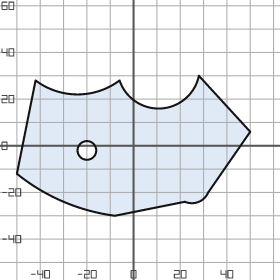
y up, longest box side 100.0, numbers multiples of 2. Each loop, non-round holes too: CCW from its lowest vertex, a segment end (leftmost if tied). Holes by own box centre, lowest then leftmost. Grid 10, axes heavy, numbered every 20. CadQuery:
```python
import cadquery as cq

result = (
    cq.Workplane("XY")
    .moveTo(-8.0, -30.0)
    .lineTo(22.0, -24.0)
    .threePointArc((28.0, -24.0), (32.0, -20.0))
    .lineTo(50.0, 6.0)
    .lineTo(28.0, 30.0)
    .threePointArc((12.0, 16.0), (-6.0, 28.0))
    .threePointArc((-24.0, 22.0), (-42.0, 28.0))
    .lineTo(-50.0, -12.0)
    .threePointArc((-30.0, -24.0), (-8.0, -30.0))
    .close()
    .moveTo(-20.0, -2.0)
    .circle(4.0)
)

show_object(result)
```